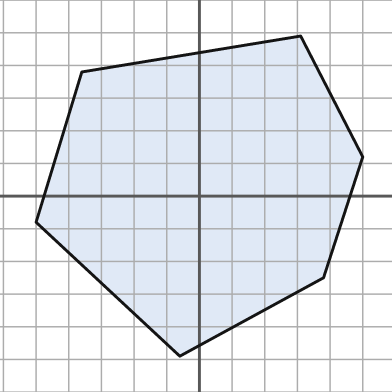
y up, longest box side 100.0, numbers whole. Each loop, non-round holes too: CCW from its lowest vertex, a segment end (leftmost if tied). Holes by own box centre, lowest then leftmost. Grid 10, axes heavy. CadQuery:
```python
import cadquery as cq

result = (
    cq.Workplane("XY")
    .moveTo(-6.0, -49.0)
    .lineTo(38.0, -25.0)
    .lineTo(50.0, 12.0)
    .lineTo(31.0, 49.0)
    .lineTo(-36.0, 38.0)
    .lineTo(-50.0, -8.0)
    .close()
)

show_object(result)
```